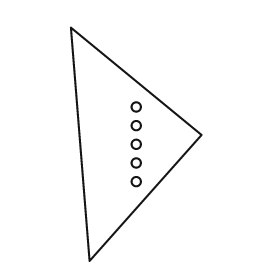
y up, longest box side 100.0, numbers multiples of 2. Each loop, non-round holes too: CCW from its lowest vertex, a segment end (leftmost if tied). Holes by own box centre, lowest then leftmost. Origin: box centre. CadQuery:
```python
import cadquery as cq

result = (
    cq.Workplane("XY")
    .moveTo(-20.0, -50.0)
    .lineTo(28.0, 4.0)
    .lineTo(-28.0, 50.0)
    .close()
    .moveTo(0.0, -16.0)
    .circle(2.0)
    .moveTo(0.0, -8.0)
    .circle(2.0)
    .moveTo(0.0, 0.0)
    .circle(2.0)
    .moveTo(0.0, 8.0)
    .circle(2.0)
    .moveTo(0.0, 16.0)
    .circle(2.0)
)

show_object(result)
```